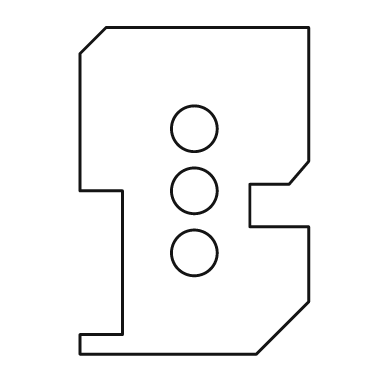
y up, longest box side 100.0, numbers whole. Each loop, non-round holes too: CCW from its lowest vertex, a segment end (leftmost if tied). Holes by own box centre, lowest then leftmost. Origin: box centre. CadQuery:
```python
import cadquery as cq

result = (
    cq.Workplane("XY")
    .moveTo(-35.0, -50.0)
    .lineTo(19.0, -50.0)
    .lineTo(35.0, -34.0)
    .lineTo(35.0, -11.0)
    .lineTo(17.0, -11.0)
    .lineTo(17.0, 2.0)
    .lineTo(29.0, 2.0)
    .lineTo(35.0, 9.0)
    .lineTo(35.0, 50.0)
    .lineTo(-27.0, 50.0)
    .lineTo(-35.0, 42.0)
    .lineTo(-35.0, 0.0)
    .lineTo(-22.0, 0.0)
    .lineTo(-22.0, -44.0)
    .lineTo(-35.0, -44.0)
    .close()
    .moveTo(0.0, -19.0)
    .circle(7.0)
    .moveTo(0.0, 0.0)
    .circle(7.0)
    .moveTo(0.0, 19.0)
    .circle(7.0)
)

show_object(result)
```